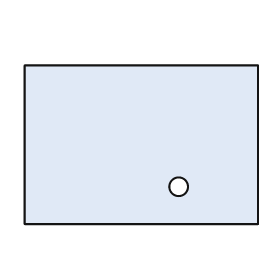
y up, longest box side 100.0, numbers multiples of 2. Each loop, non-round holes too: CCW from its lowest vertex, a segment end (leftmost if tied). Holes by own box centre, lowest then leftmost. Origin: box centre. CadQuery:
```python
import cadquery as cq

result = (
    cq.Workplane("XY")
    .moveTo(-50.0, -34.0)
    .lineTo(50.0, -34.0)
    .lineTo(50.0, 34.0)
    .lineTo(-50.0, 34.0)
    .close()
    .moveTo(16.0, -18.0)
    .circle(4.0)
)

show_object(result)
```